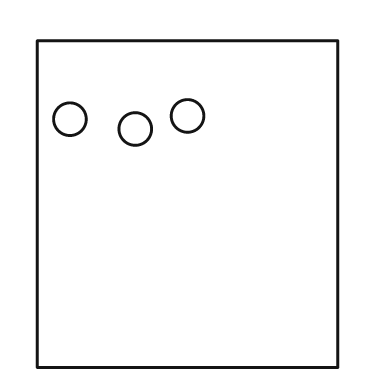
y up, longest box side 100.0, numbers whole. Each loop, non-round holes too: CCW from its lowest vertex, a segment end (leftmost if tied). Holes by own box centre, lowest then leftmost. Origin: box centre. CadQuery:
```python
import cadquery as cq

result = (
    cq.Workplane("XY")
    .moveTo(-46.0, -50.0)
    .lineTo(46.0, -50.0)
    .lineTo(46.0, 50.0)
    .lineTo(-46.0, 50.0)
    .close()
    .moveTo(-16.0, 23.0)
    .circle(5.0)
    .moveTo(-36.0, 26.0)
    .circle(5.0)
    .moveTo(0.0, 27.0)
    .circle(5.0)
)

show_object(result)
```